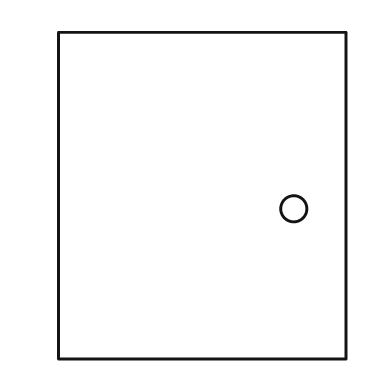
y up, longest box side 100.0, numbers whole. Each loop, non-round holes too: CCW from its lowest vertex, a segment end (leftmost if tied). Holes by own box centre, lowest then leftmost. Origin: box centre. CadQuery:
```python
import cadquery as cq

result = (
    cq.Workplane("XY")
    .moveTo(-44.0, -50.0)
    .lineTo(44.0, -50.0)
    .lineTo(44.0, 50.0)
    .lineTo(-44.0, 50.0)
    .close()
    .moveTo(28.0, -4.0)
    .circle(4.0)
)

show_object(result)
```